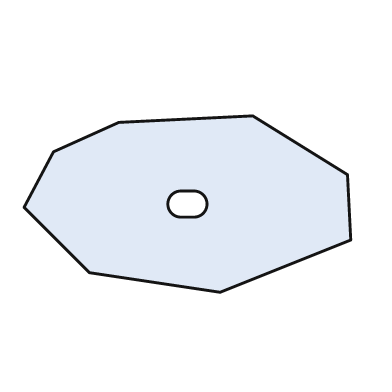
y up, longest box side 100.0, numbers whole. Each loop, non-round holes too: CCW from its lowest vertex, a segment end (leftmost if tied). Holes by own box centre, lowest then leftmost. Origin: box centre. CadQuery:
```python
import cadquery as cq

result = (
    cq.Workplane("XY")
    .moveTo(10.0, -27.0)
    .lineTo(50.0, -11.0)
    .lineTo(49.0, 9.0)
    .lineTo(20.0, 27.0)
    .lineTo(-21.0, 25.0)
    .lineTo(-41.0, 16.0)
    .lineTo(-50.0, -1.0)
    .lineTo(-30.0, -21.0)
    .close()
    .moveTo(-2.0, -4.0)
    .lineTo(2.0, -4.0)
    .threePointArc((6.0, 0.0), (2.0, 4.0))
    .lineTo(-2.0, 4.0)
    .threePointArc((-6.0, 0.0), (-2.0, -4.0))
    .close()
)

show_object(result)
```